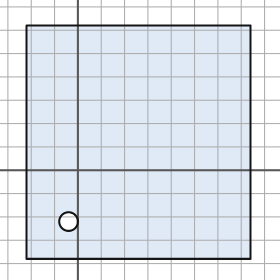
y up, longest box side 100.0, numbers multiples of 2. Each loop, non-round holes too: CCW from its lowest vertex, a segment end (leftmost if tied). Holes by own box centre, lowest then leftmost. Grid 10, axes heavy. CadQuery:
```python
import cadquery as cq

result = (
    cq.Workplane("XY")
    .moveTo(-22.0, -38.0)
    .lineTo(74.0, -38.0)
    .lineTo(74.0, 62.0)
    .lineTo(-22.0, 62.0)
    .close()
    .moveTo(-4.0, -22.0)
    .circle(4.0)
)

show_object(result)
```